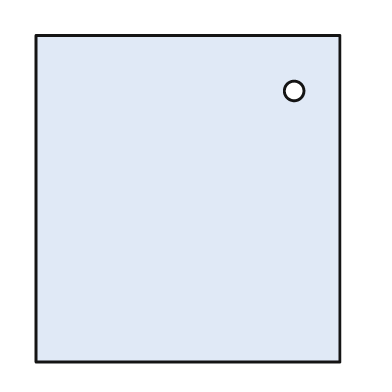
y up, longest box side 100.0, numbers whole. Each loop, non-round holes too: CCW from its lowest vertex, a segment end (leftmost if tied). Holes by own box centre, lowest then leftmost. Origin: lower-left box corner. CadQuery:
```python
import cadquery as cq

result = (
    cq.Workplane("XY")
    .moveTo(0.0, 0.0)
    .lineTo(93.0, 0.0)
    .lineTo(93.0, 100.0)
    .lineTo(0.0, 100.0)
    .close()
    .moveTo(79.0, 83.0)
    .circle(3.0)
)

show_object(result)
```